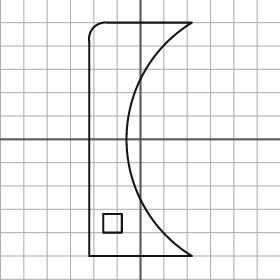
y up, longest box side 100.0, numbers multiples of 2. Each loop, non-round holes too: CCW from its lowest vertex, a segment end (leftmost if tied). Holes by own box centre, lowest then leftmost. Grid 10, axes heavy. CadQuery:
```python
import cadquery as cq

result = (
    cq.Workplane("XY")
    .moveTo(-22.0, -50.0)
    .lineTo(22.0, -50.0)
    .threePointArc((-6.0, 0.0), (22.0, 50.0))
    .lineTo(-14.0, 50.0)
    .threePointArc((-20.0, 48.0), (-22.0, 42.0))
    .close()
    .moveTo(-16.0, -40.0)
    .lineTo(-8.0, -40.0)
    .lineTo(-8.0, -32.0)
    .lineTo(-16.0, -32.0)
    .close()
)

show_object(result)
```